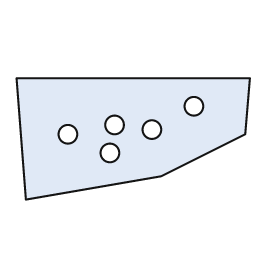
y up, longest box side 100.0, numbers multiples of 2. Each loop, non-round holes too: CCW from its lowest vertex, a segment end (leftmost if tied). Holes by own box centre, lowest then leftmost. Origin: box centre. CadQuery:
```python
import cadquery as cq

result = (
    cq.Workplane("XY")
    .moveTo(-46.0, -26.0)
    .lineTo(12.0, -16.0)
    .lineTo(48.0, 2.0)
    .lineTo(50.0, 26.0)
    .lineTo(-50.0, 26.0)
    .close()
    .moveTo(-10.0, -6.0)
    .circle(4.0)
    .moveTo(-28.0, 2.0)
    .circle(4.0)
    .moveTo(8.0, 4.0)
    .circle(4.0)
    .moveTo(-8.0, 6.0)
    .circle(4.0)
    .moveTo(26.0, 14.0)
    .circle(4.0)
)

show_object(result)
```